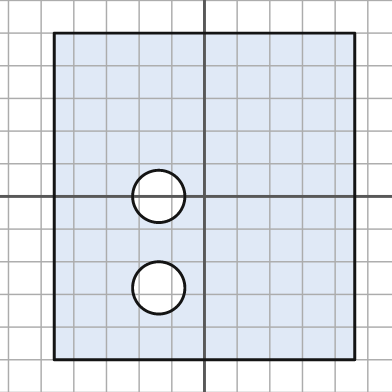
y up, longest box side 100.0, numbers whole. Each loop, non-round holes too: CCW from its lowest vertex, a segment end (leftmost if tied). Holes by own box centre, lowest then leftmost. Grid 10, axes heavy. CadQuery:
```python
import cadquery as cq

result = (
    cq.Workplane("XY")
    .moveTo(-46.0, -50.0)
    .lineTo(46.0, -50.0)
    .lineTo(46.0, 50.0)
    .lineTo(-46.0, 50.0)
    .close()
    .moveTo(-14.0, -28.0)
    .circle(8.0)
    .moveTo(-14.0, 0.0)
    .circle(8.0)
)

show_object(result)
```